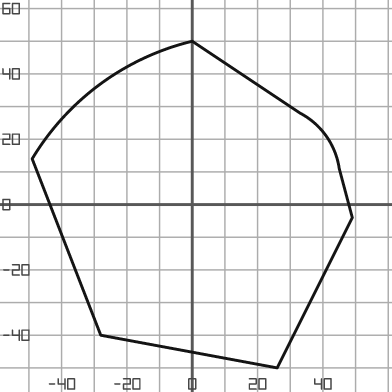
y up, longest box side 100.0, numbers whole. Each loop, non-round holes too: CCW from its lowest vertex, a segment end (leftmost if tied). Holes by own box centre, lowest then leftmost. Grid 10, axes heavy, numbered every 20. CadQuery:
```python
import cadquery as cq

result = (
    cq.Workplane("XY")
    .moveTo(26.0, -50.0)
    .lineTo(49.0, -4.0)
    .lineTo(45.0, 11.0)
    .threePointArc((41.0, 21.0), (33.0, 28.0))
    .lineTo(0.0, 50.0)
    .threePointArc((-28.0, 37.0), (-49.0, 14.0))
    .lineTo(-28.0, -40.0)
    .close()
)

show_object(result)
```